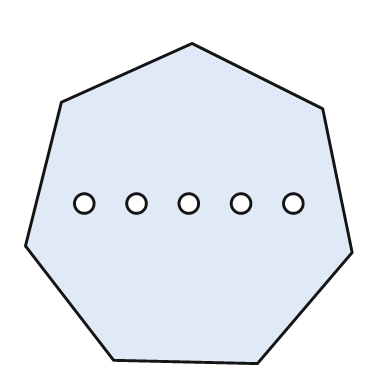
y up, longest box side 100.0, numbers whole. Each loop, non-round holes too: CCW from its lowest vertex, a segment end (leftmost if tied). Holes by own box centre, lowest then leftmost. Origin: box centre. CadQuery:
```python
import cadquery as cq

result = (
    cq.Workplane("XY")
    .moveTo(21.0, -49.0)
    .lineTo(50.0, -15.0)
    .lineTo(41.0, 29.0)
    .lineTo(1.0, 49.0)
    .lineTo(-39.0, 31.0)
    .lineTo(-50.0, -13.0)
    .lineTo(-23.0, -48.0)
    .close()
    .moveTo(-32.0, 0.0)
    .circle(3.0)
    .moveTo(-16.0, 0.0)
    .circle(3.0)
    .moveTo(0.0, 0.0)
    .circle(3.0)
    .moveTo(16.0, 0.0)
    .circle(3.0)
    .moveTo(32.0, 0.0)
    .circle(3.0)
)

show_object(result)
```